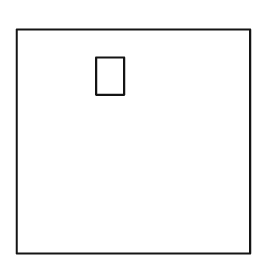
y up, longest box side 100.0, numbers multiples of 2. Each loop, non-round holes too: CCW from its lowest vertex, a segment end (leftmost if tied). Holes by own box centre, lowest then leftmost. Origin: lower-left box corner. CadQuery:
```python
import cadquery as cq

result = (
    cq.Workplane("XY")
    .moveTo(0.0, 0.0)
    .lineTo(100.0, 0.0)
    .lineTo(100.0, 96.0)
    .lineTo(0.0, 96.0)
    .close()
    .moveTo(34.0, 68.0)
    .lineTo(46.0, 68.0)
    .lineTo(46.0, 84.0)
    .lineTo(34.0, 84.0)
    .close()
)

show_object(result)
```